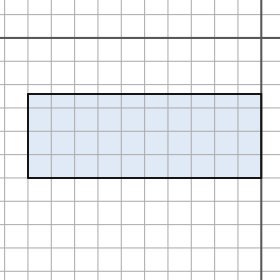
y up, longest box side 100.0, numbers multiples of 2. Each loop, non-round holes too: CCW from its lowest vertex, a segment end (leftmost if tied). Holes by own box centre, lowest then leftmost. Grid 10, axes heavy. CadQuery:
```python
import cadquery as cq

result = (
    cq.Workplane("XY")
    .moveTo(-100.0, -60.0)
    .lineTo(0.0, -60.0)
    .lineTo(0.0, -24.0)
    .lineTo(-100.0, -24.0)
    .close()
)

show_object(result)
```